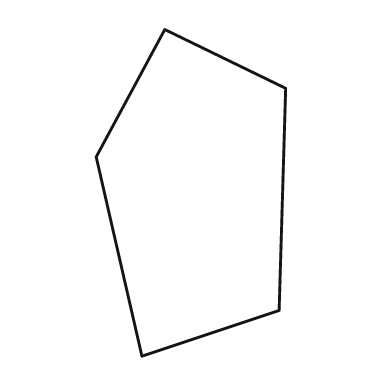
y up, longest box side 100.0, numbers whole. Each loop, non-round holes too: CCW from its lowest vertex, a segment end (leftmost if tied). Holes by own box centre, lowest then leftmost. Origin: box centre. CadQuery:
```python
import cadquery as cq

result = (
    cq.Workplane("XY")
    .moveTo(-15.0, -50.0)
    .lineTo(27.0, -36.0)
    .lineTo(29.0, 32.0)
    .lineTo(-8.0, 50.0)
    .lineTo(-29.0, 11.0)
    .close()
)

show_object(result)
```